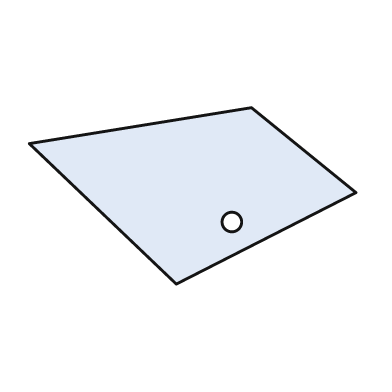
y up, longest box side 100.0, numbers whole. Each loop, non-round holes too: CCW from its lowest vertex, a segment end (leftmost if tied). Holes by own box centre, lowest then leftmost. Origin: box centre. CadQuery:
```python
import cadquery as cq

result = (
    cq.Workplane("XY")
    .moveTo(-5.0, -27.0)
    .lineTo(50.0, 1.0)
    .lineTo(18.0, 27.0)
    .lineTo(-50.0, 16.0)
    .close()
    .moveTo(12.0, -8.0)
    .circle(3.0)
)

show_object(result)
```